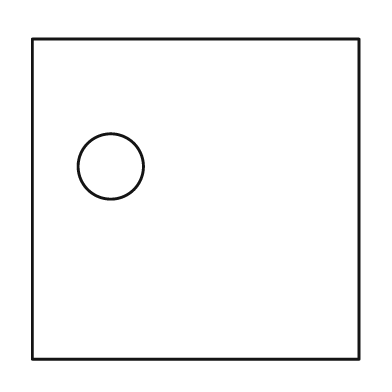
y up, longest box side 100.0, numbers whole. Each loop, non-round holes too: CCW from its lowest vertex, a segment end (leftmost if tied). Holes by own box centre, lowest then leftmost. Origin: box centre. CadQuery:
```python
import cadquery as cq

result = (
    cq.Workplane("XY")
    .moveTo(-50.0, -49.0)
    .lineTo(50.0, -49.0)
    .lineTo(50.0, 49.0)
    .lineTo(-50.0, 49.0)
    .close()
    .moveTo(-26.0, 10.0)
    .circle(10.0)
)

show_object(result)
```